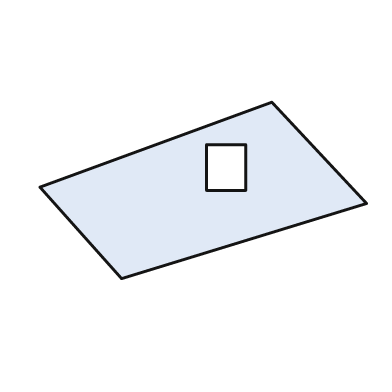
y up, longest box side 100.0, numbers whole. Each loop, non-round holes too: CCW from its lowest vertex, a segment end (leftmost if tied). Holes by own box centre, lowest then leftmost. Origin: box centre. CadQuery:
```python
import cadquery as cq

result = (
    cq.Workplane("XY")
    .moveTo(-25.0, -27.0)
    .lineTo(50.0, -4.0)
    .lineTo(21.0, 27.0)
    .lineTo(-50.0, 1.0)
    .close()
    .moveTo(1.0, 0.0)
    .lineTo(13.0, 0.0)
    .lineTo(13.0, 14.0)
    .lineTo(1.0, 14.0)
    .close()
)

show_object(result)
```